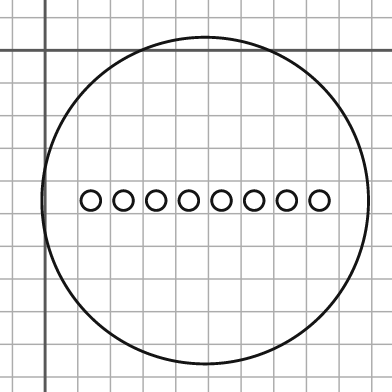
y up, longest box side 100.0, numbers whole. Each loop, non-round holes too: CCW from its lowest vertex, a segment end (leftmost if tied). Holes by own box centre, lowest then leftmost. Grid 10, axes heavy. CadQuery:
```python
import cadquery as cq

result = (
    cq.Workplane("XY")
    .moveTo(49.0, -46.0)
    .circle(50.0)
    .moveTo(14.0, -46.0)
    .circle(3.0)
    .moveTo(24.0, -46.0)
    .circle(3.0)
    .moveTo(34.0, -46.0)
    .circle(3.0)
    .moveTo(44.0, -46.0)
    .circle(3.0)
    .moveTo(54.0, -46.0)
    .circle(3.0)
    .moveTo(64.0, -46.0)
    .circle(3.0)
    .moveTo(74.0, -46.0)
    .circle(3.0)
    .moveTo(84.0, -46.0)
    .circle(3.0)
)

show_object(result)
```